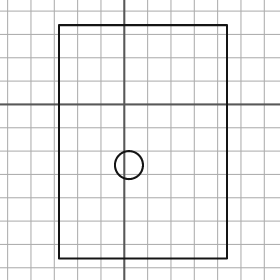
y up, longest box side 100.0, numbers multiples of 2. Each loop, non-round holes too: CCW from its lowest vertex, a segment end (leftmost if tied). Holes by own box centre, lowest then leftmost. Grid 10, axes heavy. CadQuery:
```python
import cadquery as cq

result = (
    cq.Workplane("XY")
    .moveTo(-28.0, -66.0)
    .lineTo(44.0, -66.0)
    .lineTo(44.0, 34.0)
    .lineTo(-28.0, 34.0)
    .close()
    .moveTo(2.0, -26.0)
    .circle(6.0)
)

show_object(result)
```